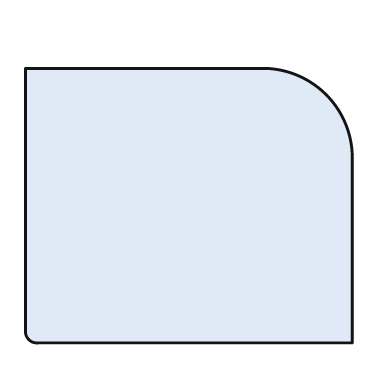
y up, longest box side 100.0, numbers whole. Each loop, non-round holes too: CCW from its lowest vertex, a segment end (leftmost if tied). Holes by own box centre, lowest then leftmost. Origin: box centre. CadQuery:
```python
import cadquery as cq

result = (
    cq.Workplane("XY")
    .moveTo(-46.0, -42.0)
    .lineTo(50.0, -42.0)
    .lineTo(50.0, 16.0)
    .threePointArc((42.0, 34.0), (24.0, 42.0))
    .lineTo(-50.0, 42.0)
    .lineTo(-50.0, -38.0)
    .threePointArc((-49.0, -41.0), (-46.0, -42.0))
    .close()
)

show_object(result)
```